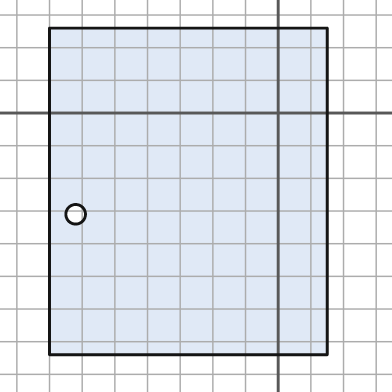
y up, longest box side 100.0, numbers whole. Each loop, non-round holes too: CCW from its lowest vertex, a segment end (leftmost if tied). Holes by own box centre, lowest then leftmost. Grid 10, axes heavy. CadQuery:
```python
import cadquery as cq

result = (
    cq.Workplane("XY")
    .moveTo(-70.0, -74.0)
    .lineTo(15.0, -74.0)
    .lineTo(15.0, 26.0)
    .lineTo(-70.0, 26.0)
    .close()
    .moveTo(-62.0, -31.0)
    .circle(3.0)
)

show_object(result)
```